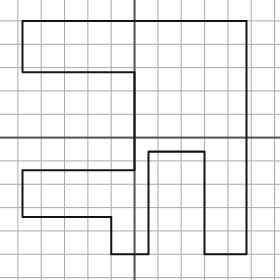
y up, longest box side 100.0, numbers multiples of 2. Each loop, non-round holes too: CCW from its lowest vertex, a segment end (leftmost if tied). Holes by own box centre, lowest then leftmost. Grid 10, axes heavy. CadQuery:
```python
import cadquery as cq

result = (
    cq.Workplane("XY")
    .moveTo(-10.0, -50.0)
    .lineTo(6.0, -50.0)
    .lineTo(6.0, -6.0)
    .lineTo(30.0, -6.0)
    .lineTo(30.0, -50.0)
    .lineTo(48.0, -50.0)
    .lineTo(48.0, 50.0)
    .lineTo(-48.0, 50.0)
    .lineTo(-48.0, 28.0)
    .lineTo(0.0, 28.0)
    .lineTo(0.0, -14.0)
    .lineTo(-48.0, -14.0)
    .lineTo(-48.0, -34.0)
    .lineTo(-10.0, -34.0)
    .close()
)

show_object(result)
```